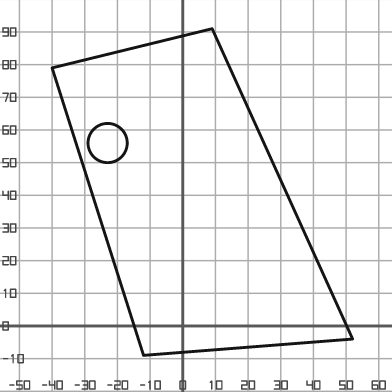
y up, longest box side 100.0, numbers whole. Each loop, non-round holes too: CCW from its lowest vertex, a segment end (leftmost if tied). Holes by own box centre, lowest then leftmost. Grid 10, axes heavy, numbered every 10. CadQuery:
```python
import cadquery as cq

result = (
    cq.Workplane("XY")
    .moveTo(-12.0, -9.0)
    .lineTo(52.0, -4.0)
    .lineTo(9.0, 91.0)
    .lineTo(-40.0, 79.0)
    .close()
    .moveTo(-23.0, 56.0)
    .circle(6.0)
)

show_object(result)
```